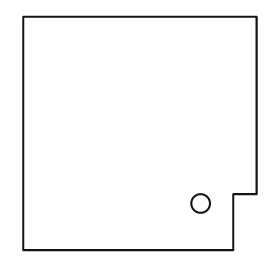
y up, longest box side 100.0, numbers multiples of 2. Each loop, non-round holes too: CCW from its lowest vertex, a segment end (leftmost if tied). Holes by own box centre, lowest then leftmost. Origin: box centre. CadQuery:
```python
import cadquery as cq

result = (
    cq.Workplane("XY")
    .moveTo(-50.0, -50.0)
    .lineTo(40.0, -50.0)
    .lineTo(40.0, -26.0)
    .lineTo(50.0, -26.0)
    .lineTo(50.0, 50.0)
    .lineTo(-50.0, 50.0)
    .close()
    .moveTo(26.0, -30.0)
    .circle(4.0)
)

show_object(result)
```